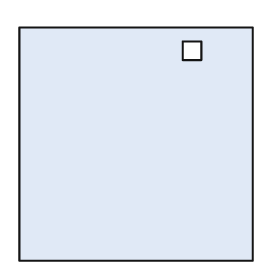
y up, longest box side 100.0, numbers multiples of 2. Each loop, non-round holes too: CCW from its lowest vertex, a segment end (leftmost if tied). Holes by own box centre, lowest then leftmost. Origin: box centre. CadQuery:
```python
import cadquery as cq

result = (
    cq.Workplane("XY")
    .moveTo(-50.0, -50.0)
    .lineTo(50.0, -50.0)
    .lineTo(50.0, 50.0)
    .lineTo(-50.0, 50.0)
    .close()
    .moveTo(20.0, 36.0)
    .lineTo(28.0, 36.0)
    .lineTo(28.0, 44.0)
    .lineTo(20.0, 44.0)
    .close()
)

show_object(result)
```